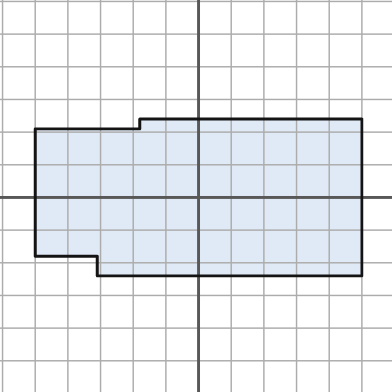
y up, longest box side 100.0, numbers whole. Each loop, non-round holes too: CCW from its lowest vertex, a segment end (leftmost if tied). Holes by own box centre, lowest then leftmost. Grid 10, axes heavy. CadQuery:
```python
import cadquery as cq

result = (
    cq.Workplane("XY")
    .moveTo(-31.0, -24.0)
    .lineTo(50.0, -24.0)
    .lineTo(50.0, 24.0)
    .lineTo(-18.0, 24.0)
    .lineTo(-18.0, 21.0)
    .lineTo(-50.0, 21.0)
    .lineTo(-50.0, -18.0)
    .lineTo(-31.0, -18.0)
    .close()
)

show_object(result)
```